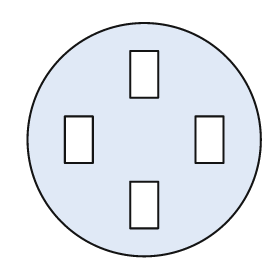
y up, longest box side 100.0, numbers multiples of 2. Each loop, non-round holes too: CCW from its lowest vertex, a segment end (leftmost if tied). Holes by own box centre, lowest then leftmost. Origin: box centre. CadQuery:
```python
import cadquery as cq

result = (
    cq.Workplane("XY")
    .moveTo(0.0, 0.0)
    .circle(50.0)
    .moveTo(-6.0, -38.0)
    .lineTo(6.0, -38.0)
    .lineTo(6.0, -18.0)
    .lineTo(-6.0, -18.0)
    .close()
    .moveTo(-34.0, -10.0)
    .lineTo(-22.0, -10.0)
    .lineTo(-22.0, 10.0)
    .lineTo(-34.0, 10.0)
    .close()
    .moveTo(22.0, -10.0)
    .lineTo(34.0, -10.0)
    .lineTo(34.0, 10.0)
    .lineTo(22.0, 10.0)
    .close()
    .moveTo(-6.0, 18.0)
    .lineTo(6.0, 18.0)
    .lineTo(6.0, 38.0)
    .lineTo(-6.0, 38.0)
    .close()
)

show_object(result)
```